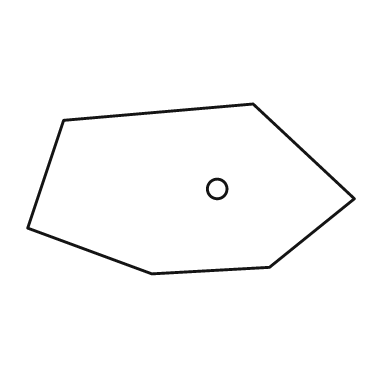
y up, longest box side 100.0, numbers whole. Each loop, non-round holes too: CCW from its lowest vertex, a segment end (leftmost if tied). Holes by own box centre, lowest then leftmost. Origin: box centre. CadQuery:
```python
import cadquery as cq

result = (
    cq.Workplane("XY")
    .moveTo(-12.0, -26.0)
    .lineTo(24.0, -24.0)
    .lineTo(50.0, -3.0)
    .lineTo(19.0, 26.0)
    .lineTo(-39.0, 21.0)
    .lineTo(-50.0, -12.0)
    .close()
    .moveTo(8.0, 0.0)
    .circle(3.0)
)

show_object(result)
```